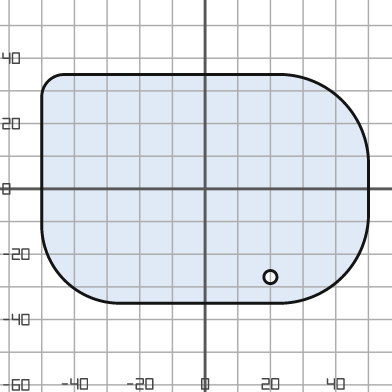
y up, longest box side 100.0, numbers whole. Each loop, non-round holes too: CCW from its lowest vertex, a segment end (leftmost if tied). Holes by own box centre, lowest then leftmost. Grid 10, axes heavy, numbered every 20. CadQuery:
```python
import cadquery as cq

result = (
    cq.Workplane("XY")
    .moveTo(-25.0, -35.0)
    .lineTo(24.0, -35.0)
    .threePointArc((42.0, -27.0), (50.0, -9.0))
    .lineTo(50.0, 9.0)
    .threePointArc((42.0, 27.0), (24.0, 35.0))
    .lineTo(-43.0, 35.0)
    .threePointArc((-48.0, 33.0), (-50.0, 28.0))
    .lineTo(-50.0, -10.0)
    .threePointArc((-43.0, -28.0), (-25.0, -35.0))
    .close()
    .moveTo(20.0, -27.0)
    .circle(2.0)
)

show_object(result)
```